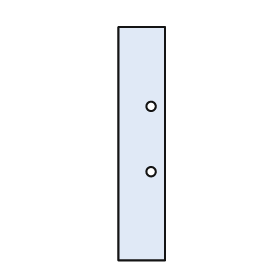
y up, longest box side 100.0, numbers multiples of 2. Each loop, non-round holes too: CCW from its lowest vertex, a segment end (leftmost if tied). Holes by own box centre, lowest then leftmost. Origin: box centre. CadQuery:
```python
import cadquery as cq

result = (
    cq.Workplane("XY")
    .moveTo(-10.0, -50.0)
    .lineTo(10.0, -50.0)
    .lineTo(10.0, 50.0)
    .lineTo(-10.0, 50.0)
    .close()
    .moveTo(4.0, -12.0)
    .circle(2.0)
    .moveTo(4.0, 16.0)
    .circle(2.0)
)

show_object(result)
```